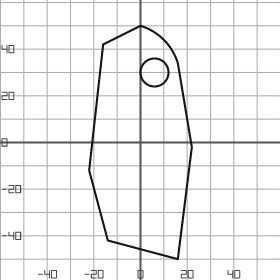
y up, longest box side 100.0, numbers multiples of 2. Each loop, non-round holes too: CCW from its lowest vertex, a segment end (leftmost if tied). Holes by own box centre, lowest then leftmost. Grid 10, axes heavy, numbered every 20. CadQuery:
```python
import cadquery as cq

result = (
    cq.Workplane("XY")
    .moveTo(16.0, -50.0)
    .lineTo(22.0, -2.0)
    .lineTo(16.0, 34.0)
    .threePointArc((10.0, 44.0), (0.0, 50.0))
    .lineTo(-16.0, 42.0)
    .lineTo(-22.0, -12.0)
    .lineTo(-14.0, -42.0)
    .close()
    .moveTo(6.0, 30.0)
    .circle(6.0)
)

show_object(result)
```